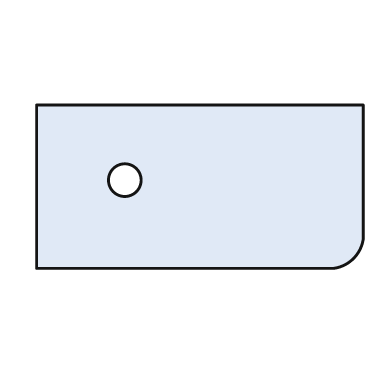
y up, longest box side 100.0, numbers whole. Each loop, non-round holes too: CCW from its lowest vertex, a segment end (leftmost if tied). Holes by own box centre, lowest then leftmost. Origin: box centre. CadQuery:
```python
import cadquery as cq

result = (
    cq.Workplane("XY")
    .moveTo(-50.0, -25.0)
    .lineTo(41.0, -25.0)
    .threePointArc((47.0, -22.0), (50.0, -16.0))
    .lineTo(50.0, 25.0)
    .lineTo(-50.0, 25.0)
    .close()
    .moveTo(-23.0, 2.0)
    .circle(5.0)
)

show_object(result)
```